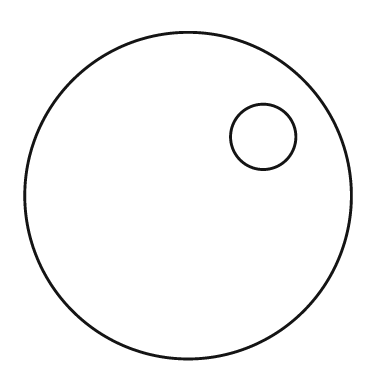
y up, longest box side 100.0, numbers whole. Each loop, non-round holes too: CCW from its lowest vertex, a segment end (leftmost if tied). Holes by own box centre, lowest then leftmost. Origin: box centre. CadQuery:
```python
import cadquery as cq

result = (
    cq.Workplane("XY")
    .moveTo(0.0, 0.0)
    .circle(50.0)
    .moveTo(23.0, 18.0)
    .circle(10.0)
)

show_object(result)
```